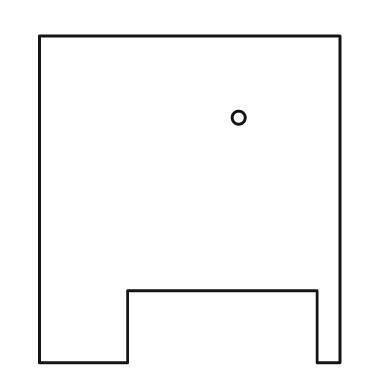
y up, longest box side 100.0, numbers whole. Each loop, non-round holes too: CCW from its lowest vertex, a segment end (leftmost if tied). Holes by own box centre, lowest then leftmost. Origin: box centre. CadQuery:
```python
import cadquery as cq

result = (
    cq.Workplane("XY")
    .moveTo(-46.0, -50.0)
    .lineTo(-19.0, -50.0)
    .lineTo(-19.0, -28.0)
    .lineTo(39.0, -28.0)
    .lineTo(39.0, -50.0)
    .lineTo(46.0, -50.0)
    .lineTo(46.0, 50.0)
    .lineTo(-46.0, 50.0)
    .close()
    .moveTo(15.0, 25.0)
    .circle(2.0)
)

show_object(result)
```